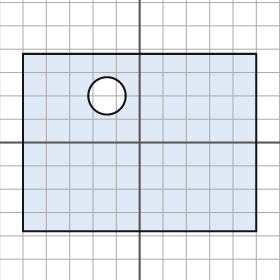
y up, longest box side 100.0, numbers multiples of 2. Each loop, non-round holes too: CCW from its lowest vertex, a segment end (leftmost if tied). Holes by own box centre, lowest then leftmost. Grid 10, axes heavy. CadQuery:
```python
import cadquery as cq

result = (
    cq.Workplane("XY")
    .moveTo(-50.0, -38.0)
    .lineTo(50.0, -38.0)
    .lineTo(50.0, 38.0)
    .lineTo(-50.0, 38.0)
    .close()
    .moveTo(-14.0, 20.0)
    .circle(8.0)
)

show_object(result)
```